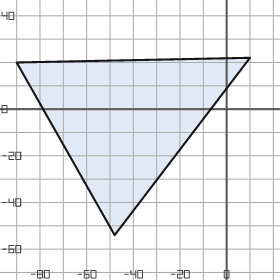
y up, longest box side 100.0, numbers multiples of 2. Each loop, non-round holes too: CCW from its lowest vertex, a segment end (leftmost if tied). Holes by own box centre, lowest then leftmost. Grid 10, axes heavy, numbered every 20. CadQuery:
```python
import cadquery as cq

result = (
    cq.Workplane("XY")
    .moveTo(-48.0, -54.0)
    .lineTo(10.0, 22.0)
    .lineTo(-90.0, 20.0)
    .close()
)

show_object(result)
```